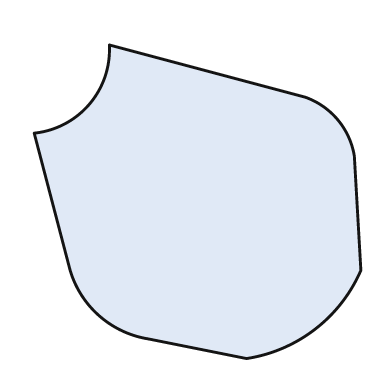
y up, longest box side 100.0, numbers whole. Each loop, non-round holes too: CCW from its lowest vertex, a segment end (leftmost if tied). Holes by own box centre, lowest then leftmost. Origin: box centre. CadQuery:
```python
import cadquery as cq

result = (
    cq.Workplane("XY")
    .moveTo(15.0, -48.0)
    .threePointArc((36.0, -39.0), (50.0, -21.0))
    .lineTo(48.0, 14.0)
    .threePointArc((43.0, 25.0), (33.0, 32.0))
    .lineTo(-27.0, 48.0)
    .threePointArc((-33.0, 30.0), (-50.0, 21.0))
    .lineTo(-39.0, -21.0)
    .threePointArc((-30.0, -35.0), (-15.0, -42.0))
    .close()
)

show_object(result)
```